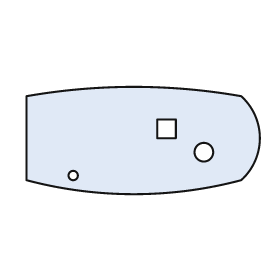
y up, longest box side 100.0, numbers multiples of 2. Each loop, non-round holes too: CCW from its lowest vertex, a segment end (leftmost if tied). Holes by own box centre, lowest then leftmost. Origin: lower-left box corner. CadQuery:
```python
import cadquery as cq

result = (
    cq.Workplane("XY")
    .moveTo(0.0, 6.0)
    .threePointArc((46.0, 0.0), (92.0, 6.0))
    .threePointArc((100.0, 24.0), (92.0, 42.0))
    .threePointArc((46.0, 46.0), (0.0, 42.0))
    .close()
    .moveTo(20.0, 8.0)
    .circle(2.0)
    .moveTo(76.0, 18.0)
    .circle(4.0)
    .moveTo(56.0, 24.0)
    .lineTo(64.0, 24.0)
    .lineTo(64.0, 32.0)
    .lineTo(56.0, 32.0)
    .close()
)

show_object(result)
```